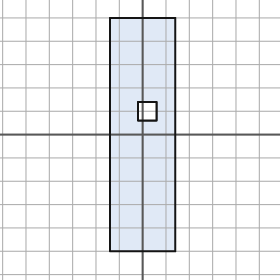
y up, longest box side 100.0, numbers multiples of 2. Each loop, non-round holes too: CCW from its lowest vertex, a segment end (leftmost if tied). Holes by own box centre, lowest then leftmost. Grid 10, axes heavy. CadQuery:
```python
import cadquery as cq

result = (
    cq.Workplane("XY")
    .moveTo(-14.0, -50.0)
    .lineTo(14.0, -50.0)
    .lineTo(14.0, 50.0)
    .lineTo(-14.0, 50.0)
    .close()
    .moveTo(-2.0, 6.0)
    .lineTo(6.0, 6.0)
    .lineTo(6.0, 14.0)
    .lineTo(-2.0, 14.0)
    .close()
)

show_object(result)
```